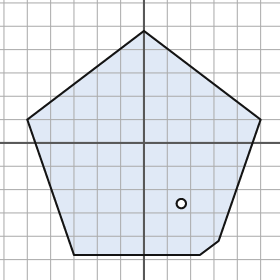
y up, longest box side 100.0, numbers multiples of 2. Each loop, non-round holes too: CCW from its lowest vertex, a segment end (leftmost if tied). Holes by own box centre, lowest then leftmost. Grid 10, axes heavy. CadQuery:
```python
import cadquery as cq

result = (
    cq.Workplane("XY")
    .moveTo(-30.0, -48.0)
    .lineTo(24.0, -48.0)
    .lineTo(32.0, -42.0)
    .lineTo(50.0, 10.0)
    .lineTo(0.0, 48.0)
    .lineTo(-50.0, 10.0)
    .close()
    .moveTo(16.0, -26.0)
    .circle(2.0)
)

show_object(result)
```